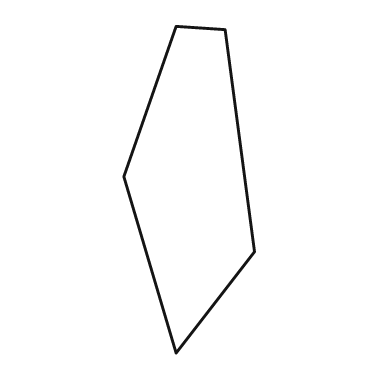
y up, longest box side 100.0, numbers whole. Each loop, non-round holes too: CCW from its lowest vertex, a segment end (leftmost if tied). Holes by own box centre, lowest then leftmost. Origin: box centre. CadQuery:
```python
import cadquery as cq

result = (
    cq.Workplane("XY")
    .moveTo(-4.0, -50.0)
    .lineTo(20.0, -19.0)
    .lineTo(11.0, 49.0)
    .lineTo(-4.0, 50.0)
    .lineTo(-20.0, 4.0)
    .close()
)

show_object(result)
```